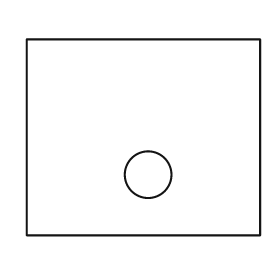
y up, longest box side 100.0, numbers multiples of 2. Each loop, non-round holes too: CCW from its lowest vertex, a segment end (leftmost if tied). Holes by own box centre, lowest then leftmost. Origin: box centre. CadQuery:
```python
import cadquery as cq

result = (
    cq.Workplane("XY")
    .moveTo(-50.0, -42.0)
    .lineTo(50.0, -42.0)
    .lineTo(50.0, 42.0)
    .lineTo(-50.0, 42.0)
    .close()
    .moveTo(2.0, -16.0)
    .circle(10.0)
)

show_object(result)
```